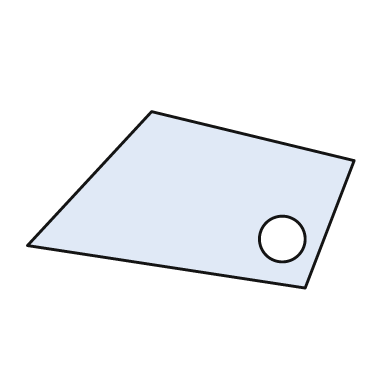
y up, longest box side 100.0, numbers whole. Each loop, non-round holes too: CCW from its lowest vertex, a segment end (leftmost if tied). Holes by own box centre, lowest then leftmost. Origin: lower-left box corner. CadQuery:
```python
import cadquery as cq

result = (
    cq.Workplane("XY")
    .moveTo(85.0, 0.0)
    .lineTo(100.0, 39.0)
    .lineTo(38.0, 54.0)
    .lineTo(0.0, 13.0)
    .close()
    .moveTo(78.0, 15.0)
    .circle(7.0)
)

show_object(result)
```